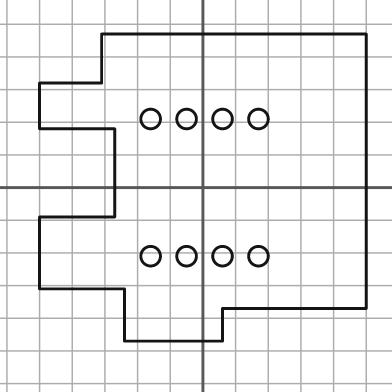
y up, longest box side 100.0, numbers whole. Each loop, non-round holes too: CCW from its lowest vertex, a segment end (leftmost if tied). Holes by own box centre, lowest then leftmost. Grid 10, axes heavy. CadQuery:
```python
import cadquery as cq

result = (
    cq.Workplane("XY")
    .moveTo(-24.0, -47.0)
    .lineTo(6.0, -47.0)
    .lineTo(6.0, -37.0)
    .lineTo(50.0, -37.0)
    .lineTo(50.0, 47.0)
    .lineTo(-31.0, 47.0)
    .lineTo(-31.0, 32.0)
    .lineTo(-50.0, 32.0)
    .lineTo(-50.0, 18.0)
    .lineTo(-27.0, 18.0)
    .lineTo(-27.0, -9.0)
    .lineTo(-50.0, -9.0)
    .lineTo(-50.0, -31.0)
    .lineTo(-24.0, -31.0)
    .close()
    .moveTo(-16.0, -21.0)
    .circle(3.0)
    .moveTo(-5.0, -21.0)
    .circle(3.0)
    .moveTo(6.0, -21.0)
    .circle(3.0)
    .moveTo(17.0, -21.0)
    .circle(3.0)
    .moveTo(-16.0, 21.0)
    .circle(3.0)
    .moveTo(-5.0, 21.0)
    .circle(3.0)
    .moveTo(6.0, 21.0)
    .circle(3.0)
    .moveTo(17.0, 21.0)
    .circle(3.0)
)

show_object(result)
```